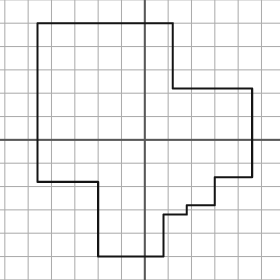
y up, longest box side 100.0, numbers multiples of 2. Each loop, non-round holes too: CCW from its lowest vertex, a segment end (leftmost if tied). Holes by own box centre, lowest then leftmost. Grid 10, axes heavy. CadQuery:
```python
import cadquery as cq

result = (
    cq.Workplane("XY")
    .moveTo(-20.0, -50.0)
    .lineTo(8.0, -50.0)
    .lineTo(8.0, -32.0)
    .lineTo(18.0, -32.0)
    .lineTo(18.0, -28.0)
    .lineTo(30.0, -28.0)
    .lineTo(30.0, -16.0)
    .lineTo(46.0, -16.0)
    .lineTo(46.0, 22.0)
    .lineTo(12.0, 22.0)
    .lineTo(12.0, 50.0)
    .lineTo(-46.0, 50.0)
    .lineTo(-46.0, -18.0)
    .lineTo(-20.0, -18.0)
    .close()
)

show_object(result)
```